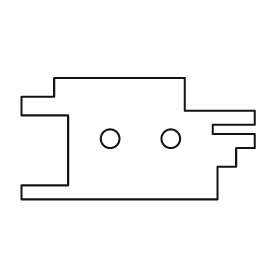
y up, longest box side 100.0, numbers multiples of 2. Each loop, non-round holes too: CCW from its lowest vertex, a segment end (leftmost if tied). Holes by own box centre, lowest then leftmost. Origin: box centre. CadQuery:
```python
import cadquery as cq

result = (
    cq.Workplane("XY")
    .moveTo(-50.0, -26.0)
    .lineTo(34.0, -26.0)
    .lineTo(34.0, -12.0)
    .lineTo(42.0, -12.0)
    .lineTo(42.0, -4.0)
    .lineTo(50.0, -4.0)
    .lineTo(50.0, 2.0)
    .lineTo(32.0, 2.0)
    .lineTo(32.0, 6.0)
    .lineTo(50.0, 6.0)
    .lineTo(50.0, 12.0)
    .lineTo(20.0, 12.0)
    .lineTo(20.0, 26.0)
    .lineTo(-36.0, 26.0)
    .lineTo(-36.0, 18.0)
    .lineTo(-50.0, 18.0)
    .lineTo(-50.0, 10.0)
    .lineTo(-30.0, 10.0)
    .lineTo(-30.0, -20.0)
    .lineTo(-50.0, -20.0)
    .close()
    .moveTo(-12.0, 0.0)
    .circle(4.0)
    .moveTo(14.0, 0.0)
    .circle(4.0)
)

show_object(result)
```